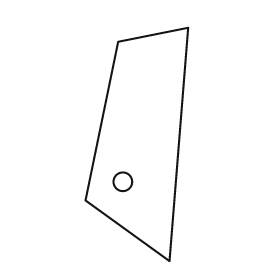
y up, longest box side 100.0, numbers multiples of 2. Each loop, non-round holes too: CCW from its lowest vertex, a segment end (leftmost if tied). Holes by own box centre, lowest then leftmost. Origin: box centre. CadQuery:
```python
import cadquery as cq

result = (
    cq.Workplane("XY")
    .moveTo(14.0, -50.0)
    .lineTo(22.0, 50.0)
    .lineTo(-8.0, 44.0)
    .lineTo(-22.0, -24.0)
    .close()
    .moveTo(-6.0, -16.0)
    .circle(4.0)
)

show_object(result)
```